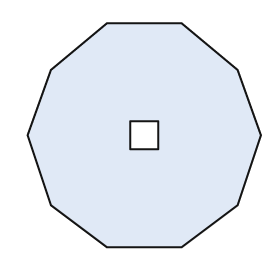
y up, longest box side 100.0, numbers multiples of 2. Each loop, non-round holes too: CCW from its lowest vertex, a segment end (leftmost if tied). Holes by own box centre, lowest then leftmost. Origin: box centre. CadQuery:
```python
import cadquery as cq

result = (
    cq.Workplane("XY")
    .moveTo(-16.0, -48.0)
    .lineTo(16.0, -48.0)
    .lineTo(40.0, -30.0)
    .lineTo(50.0, 0.0)
    .lineTo(40.0, 28.0)
    .lineTo(16.0, 48.0)
    .lineTo(-16.0, 48.0)
    .lineTo(-40.0, 28.0)
    .lineTo(-50.0, 0.0)
    .lineTo(-40.0, -30.0)
    .close()
    .moveTo(-6.0, -6.0)
    .lineTo(6.0, -6.0)
    .lineTo(6.0, 6.0)
    .lineTo(-6.0, 6.0)
    .close()
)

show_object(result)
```